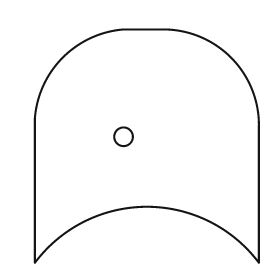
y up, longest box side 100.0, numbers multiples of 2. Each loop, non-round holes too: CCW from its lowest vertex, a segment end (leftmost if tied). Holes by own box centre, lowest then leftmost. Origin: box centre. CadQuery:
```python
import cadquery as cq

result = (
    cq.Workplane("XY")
    .moveTo(-48.0, -50.0)
    .threePointArc((0.0, -26.0), (48.0, -50.0))
    .lineTo(48.0, 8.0)
    .threePointArc((36.0, 38.0), (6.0, 50.0))
    .lineTo(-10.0, 50.0)
    .threePointArc((-36.0, 38.0), (-48.0, 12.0))
    .close()
    .moveTo(-10.0, 4.0)
    .circle(4.0)
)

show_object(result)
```